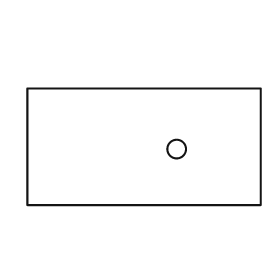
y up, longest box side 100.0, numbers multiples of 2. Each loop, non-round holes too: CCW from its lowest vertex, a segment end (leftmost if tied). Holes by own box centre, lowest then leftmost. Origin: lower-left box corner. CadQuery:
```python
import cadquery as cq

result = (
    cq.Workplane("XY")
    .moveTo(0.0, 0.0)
    .lineTo(100.0, 0.0)
    .lineTo(100.0, 50.0)
    .lineTo(0.0, 50.0)
    .close()
    .moveTo(64.0, 24.0)
    .circle(4.0)
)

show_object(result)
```